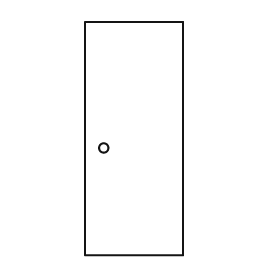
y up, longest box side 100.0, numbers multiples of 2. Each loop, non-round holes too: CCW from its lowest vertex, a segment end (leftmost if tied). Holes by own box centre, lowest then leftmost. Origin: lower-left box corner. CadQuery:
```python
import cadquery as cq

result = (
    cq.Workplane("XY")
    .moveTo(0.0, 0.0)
    .lineTo(42.0, 0.0)
    .lineTo(42.0, 100.0)
    .lineTo(0.0, 100.0)
    .close()
    .moveTo(8.0, 46.0)
    .circle(2.0)
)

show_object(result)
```